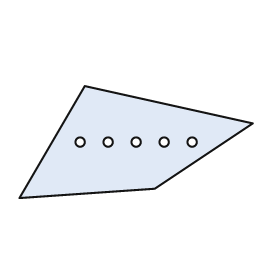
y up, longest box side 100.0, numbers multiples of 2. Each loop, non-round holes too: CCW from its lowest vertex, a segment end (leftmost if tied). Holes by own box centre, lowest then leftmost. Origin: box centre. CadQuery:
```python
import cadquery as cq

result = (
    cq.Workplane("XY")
    .moveTo(-50.0, -24.0)
    .lineTo(8.0, -20.0)
    .lineTo(50.0, 8.0)
    .lineTo(-22.0, 24.0)
    .close()
    .moveTo(-24.0, 0.0)
    .circle(2.0)
    .moveTo(-12.0, 0.0)
    .circle(2.0)
    .moveTo(0.0, 0.0)
    .circle(2.0)
    .moveTo(12.0, 0.0)
    .circle(2.0)
    .moveTo(24.0, 0.0)
    .circle(2.0)
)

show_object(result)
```